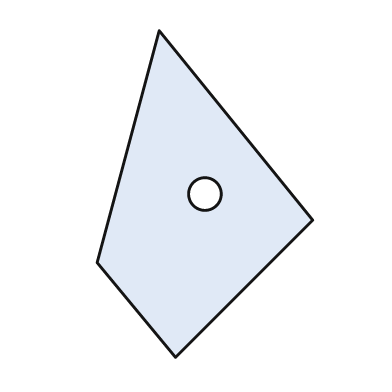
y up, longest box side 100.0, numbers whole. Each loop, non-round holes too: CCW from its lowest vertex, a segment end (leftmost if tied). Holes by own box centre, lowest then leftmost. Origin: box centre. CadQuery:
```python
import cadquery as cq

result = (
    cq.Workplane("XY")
    .moveTo(-9.0, -50.0)
    .lineTo(33.0, -8.0)
    .lineTo(-14.0, 50.0)
    .lineTo(-33.0, -21.0)
    .close()
    .moveTo(0.0, 0.0)
    .circle(5.0)
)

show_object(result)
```